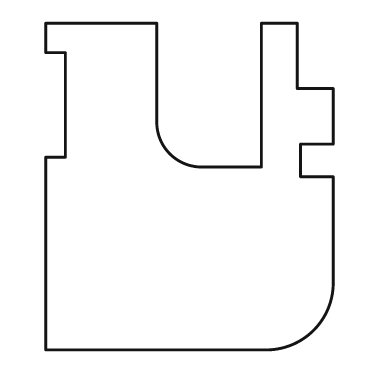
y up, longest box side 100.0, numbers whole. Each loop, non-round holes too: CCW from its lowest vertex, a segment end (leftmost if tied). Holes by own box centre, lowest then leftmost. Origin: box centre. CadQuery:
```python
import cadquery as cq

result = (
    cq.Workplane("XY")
    .moveTo(-44.0, -50.0)
    .lineTo(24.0, -50.0)
    .threePointArc((38.0, -44.0), (44.0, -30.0))
    .lineTo(44.0, 3.0)
    .lineTo(34.0, 3.0)
    .lineTo(34.0, 13.0)
    .lineTo(44.0, 13.0)
    .lineTo(44.0, 30.0)
    .lineTo(33.0, 30.0)
    .lineTo(33.0, 50.0)
    .lineTo(22.0, 50.0)
    .lineTo(22.0, 6.0)
    .lineTo(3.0, 6.0)
    .threePointArc((-6.0, 10.0), (-10.0, 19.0))
    .lineTo(-10.0, 50.0)
    .lineTo(-44.0, 50.0)
    .lineTo(-44.0, 41.0)
    .lineTo(-38.0, 41.0)
    .lineTo(-38.0, 9.0)
    .lineTo(-44.0, 9.0)
    .close()
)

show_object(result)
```